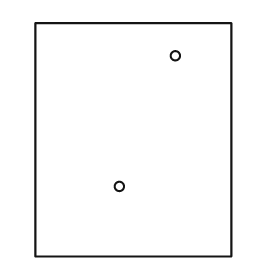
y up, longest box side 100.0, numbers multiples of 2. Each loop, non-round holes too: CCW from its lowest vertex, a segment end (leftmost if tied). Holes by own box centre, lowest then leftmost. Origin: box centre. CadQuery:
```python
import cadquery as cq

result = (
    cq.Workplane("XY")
    .moveTo(-42.0, -50.0)
    .lineTo(42.0, -50.0)
    .lineTo(42.0, 50.0)
    .lineTo(-42.0, 50.0)
    .close()
    .moveTo(-6.0, -20.0)
    .circle(2.0)
    .moveTo(18.0, 36.0)
    .circle(2.0)
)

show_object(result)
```